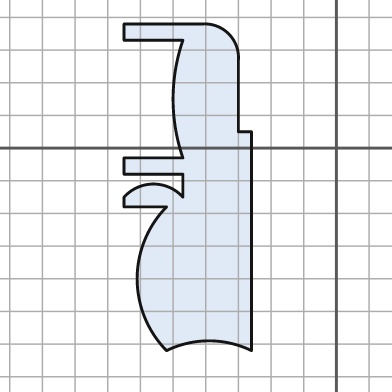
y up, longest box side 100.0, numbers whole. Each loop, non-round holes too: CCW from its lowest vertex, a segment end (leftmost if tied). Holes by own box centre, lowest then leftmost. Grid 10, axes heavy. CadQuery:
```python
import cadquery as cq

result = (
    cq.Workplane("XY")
    .moveTo(-52.0, -62.0)
    .threePointArc((-39.0, -59.0), (-26.0, -62.0))
    .lineTo(-26.0, 5.0)
    .lineTo(-30.0, 5.0)
    .lineTo(-30.0, 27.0)
    .threePointArc((-33.0, 35.0), (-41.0, 38.0))
    .lineTo(-65.0, 38.0)
    .lineTo(-65.0, 33.0)
    .lineTo(-47.0, 33.0)
    .threePointArc((-50.0, 15.0), (-47.0, -3.0))
    .lineTo(-65.0, -3.0)
    .lineTo(-65.0, -8.0)
    .lineTo(-47.0, -8.0)
    .lineTo(-47.0, -15.0)
    .threePointArc((-56.0, -11.0), (-65.0, -15.0))
    .lineTo(-65.0, -18.0)
    .lineTo(-52.0, -18.0)
    .threePointArc((-61.0, -40.0), (-52.0, -62.0))
    .close()
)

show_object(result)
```